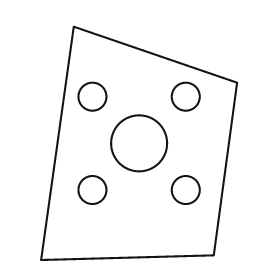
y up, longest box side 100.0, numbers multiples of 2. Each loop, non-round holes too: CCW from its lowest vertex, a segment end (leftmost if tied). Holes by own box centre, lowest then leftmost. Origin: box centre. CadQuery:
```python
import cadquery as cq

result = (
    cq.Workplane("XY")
    .moveTo(-42.0, -50.0)
    .lineTo(32.0, -48.0)
    .lineTo(42.0, 26.0)
    .lineTo(-28.0, 50.0)
    .close()
    .moveTo(-20.0, -20.0)
    .circle(6.0)
    .moveTo(20.0, -20.0)
    .circle(6.0)
    .moveTo(0.0, 0.0)
    .circle(12.0)
    .moveTo(-20.0, 20.0)
    .circle(6.0)
    .moveTo(20.0, 20.0)
    .circle(6.0)
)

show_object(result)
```